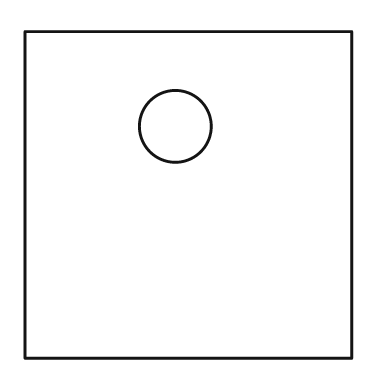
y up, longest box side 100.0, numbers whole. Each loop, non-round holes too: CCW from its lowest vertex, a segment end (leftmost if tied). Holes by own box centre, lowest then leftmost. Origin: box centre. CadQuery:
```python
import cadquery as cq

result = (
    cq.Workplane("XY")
    .moveTo(-50.0, -50.0)
    .lineTo(50.0, -50.0)
    .lineTo(50.0, 50.0)
    .lineTo(-50.0, 50.0)
    .close()
    .moveTo(-4.0, 21.0)
    .circle(11.0)
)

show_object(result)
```